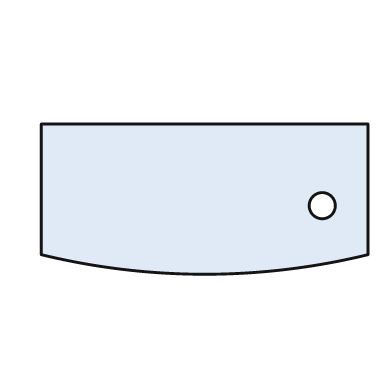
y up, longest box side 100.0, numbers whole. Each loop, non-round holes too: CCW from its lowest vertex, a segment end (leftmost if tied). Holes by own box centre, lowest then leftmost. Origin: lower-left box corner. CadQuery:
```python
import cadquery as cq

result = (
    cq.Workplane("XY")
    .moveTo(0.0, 6.0)
    .threePointArc((50.0, 0.0), (100.0, 6.0))
    .lineTo(100.0, 46.0)
    .lineTo(0.0, 46.0)
    .close()
    .moveTo(86.0, 21.0)
    .circle(4.0)
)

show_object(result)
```